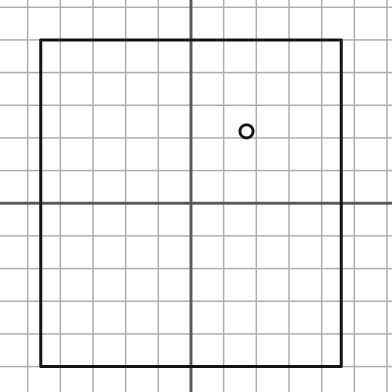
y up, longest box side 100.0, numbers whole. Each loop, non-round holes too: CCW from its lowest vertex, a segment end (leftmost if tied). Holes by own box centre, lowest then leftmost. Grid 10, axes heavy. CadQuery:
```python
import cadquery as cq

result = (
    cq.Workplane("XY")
    .moveTo(-46.0, -50.0)
    .lineTo(46.0, -50.0)
    .lineTo(46.0, 50.0)
    .lineTo(-46.0, 50.0)
    .close()
    .moveTo(17.0, 22.0)
    .circle(2.0)
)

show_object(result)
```